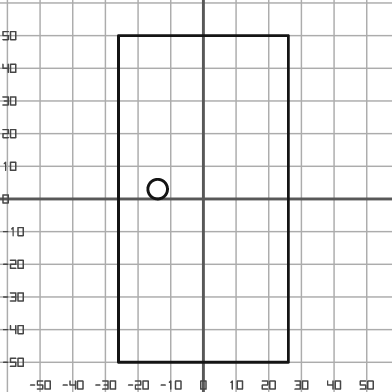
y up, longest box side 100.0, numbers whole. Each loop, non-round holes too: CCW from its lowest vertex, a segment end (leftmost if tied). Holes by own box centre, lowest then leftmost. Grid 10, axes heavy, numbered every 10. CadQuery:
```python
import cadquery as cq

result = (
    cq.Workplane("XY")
    .moveTo(-26.0, -50.0)
    .lineTo(26.0, -50.0)
    .lineTo(26.0, 50.0)
    .lineTo(-26.0, 50.0)
    .close()
    .moveTo(-14.0, 3.0)
    .circle(3.0)
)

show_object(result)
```